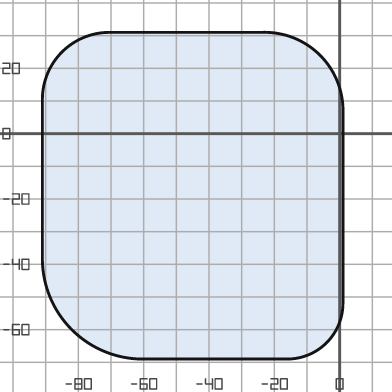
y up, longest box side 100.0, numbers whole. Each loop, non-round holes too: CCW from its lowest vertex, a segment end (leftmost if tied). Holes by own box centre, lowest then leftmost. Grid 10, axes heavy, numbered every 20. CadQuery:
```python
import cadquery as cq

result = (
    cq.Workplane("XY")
    .moveTo(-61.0, -69.0)
    .lineTo(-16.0, -69.0)
    .threePointArc((-4.0, -64.0), (1.0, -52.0))
    .lineTo(1.0, 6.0)
    .threePointArc((-6.0, 24.0), (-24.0, 31.0))
    .lineTo(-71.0, 31.0)
    .threePointArc((-85.0, 25.0), (-91.0, 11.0))
    .lineTo(-91.0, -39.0)
    .threePointArc((-82.0, -60.0), (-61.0, -69.0))
    .close()
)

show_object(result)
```